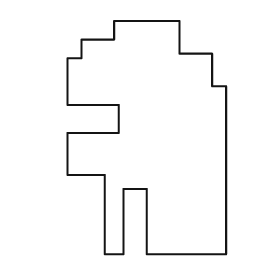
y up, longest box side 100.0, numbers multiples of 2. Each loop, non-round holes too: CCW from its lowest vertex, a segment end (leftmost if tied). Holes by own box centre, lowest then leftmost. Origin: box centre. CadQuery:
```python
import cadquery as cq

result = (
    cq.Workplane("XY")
    .moveTo(-18.0, -50.0)
    .lineTo(-10.0, -50.0)
    .lineTo(-10.0, -22.0)
    .lineTo(0.0, -22.0)
    .lineTo(0.0, -50.0)
    .lineTo(34.0, -50.0)
    .lineTo(34.0, 22.0)
    .lineTo(28.0, 22.0)
    .lineTo(28.0, 36.0)
    .lineTo(14.0, 36.0)
    .lineTo(14.0, 50.0)
    .lineTo(-14.0, 50.0)
    .lineTo(-14.0, 42.0)
    .lineTo(-28.0, 42.0)
    .lineTo(-28.0, 34.0)
    .lineTo(-34.0, 34.0)
    .lineTo(-34.0, 14.0)
    .lineTo(-12.0, 14.0)
    .lineTo(-12.0, 2.0)
    .lineTo(-34.0, 2.0)
    .lineTo(-34.0, -16.0)
    .lineTo(-18.0, -16.0)
    .close()
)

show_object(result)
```